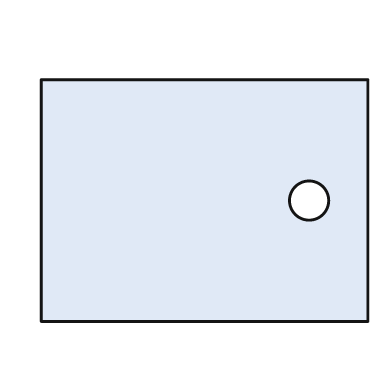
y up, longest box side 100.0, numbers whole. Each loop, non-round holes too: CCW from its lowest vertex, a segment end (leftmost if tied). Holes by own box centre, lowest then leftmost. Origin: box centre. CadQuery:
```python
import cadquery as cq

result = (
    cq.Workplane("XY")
    .moveTo(-50.0, -37.0)
    .lineTo(50.0, -37.0)
    .lineTo(50.0, 37.0)
    .lineTo(-50.0, 37.0)
    .close()
    .moveTo(32.0, 0.0)
    .circle(6.0)
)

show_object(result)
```